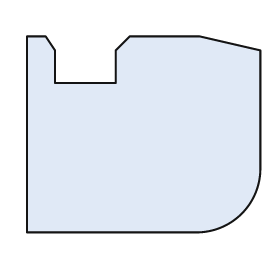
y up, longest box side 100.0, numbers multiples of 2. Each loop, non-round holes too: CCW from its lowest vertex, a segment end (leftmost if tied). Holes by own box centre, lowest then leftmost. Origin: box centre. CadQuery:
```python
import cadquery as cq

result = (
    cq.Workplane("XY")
    .moveTo(-50.0, -42.0)
    .lineTo(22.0, -42.0)
    .threePointArc((42.0, -34.0), (50.0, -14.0))
    .lineTo(50.0, 36.0)
    .lineTo(24.0, 42.0)
    .lineTo(-6.0, 42.0)
    .lineTo(-12.0, 36.0)
    .lineTo(-12.0, 22.0)
    .lineTo(-38.0, 22.0)
    .lineTo(-38.0, 36.0)
    .lineTo(-42.0, 42.0)
    .lineTo(-50.0, 42.0)
    .close()
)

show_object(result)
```